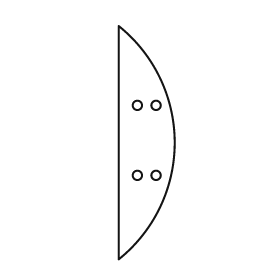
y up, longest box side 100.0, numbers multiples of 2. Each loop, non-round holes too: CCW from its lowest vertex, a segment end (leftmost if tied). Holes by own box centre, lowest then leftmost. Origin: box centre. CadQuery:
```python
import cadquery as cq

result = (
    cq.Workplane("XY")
    .moveTo(-12.0, -50.0)
    .threePointArc((12.0, 0.0), (-12.0, 50.0))
    .close()
    .moveTo(-4.0, -14.0)
    .circle(2.0)
    .moveTo(4.0, -14.0)
    .circle(2.0)
    .moveTo(-4.0, 16.0)
    .circle(2.0)
    .moveTo(4.0, 16.0)
    .circle(2.0)
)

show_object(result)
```